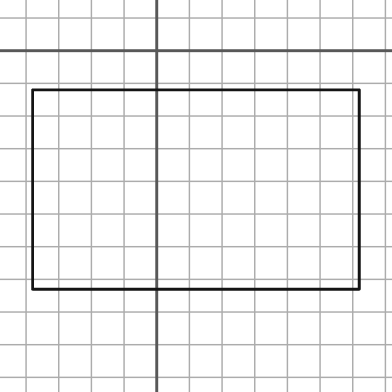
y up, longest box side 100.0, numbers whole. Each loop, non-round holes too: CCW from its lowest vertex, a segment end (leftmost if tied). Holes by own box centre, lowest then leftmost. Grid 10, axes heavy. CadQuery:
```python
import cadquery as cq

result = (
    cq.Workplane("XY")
    .moveTo(-38.0, -73.0)
    .lineTo(62.0, -73.0)
    .lineTo(62.0, -12.0)
    .lineTo(-38.0, -12.0)
    .close()
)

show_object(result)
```